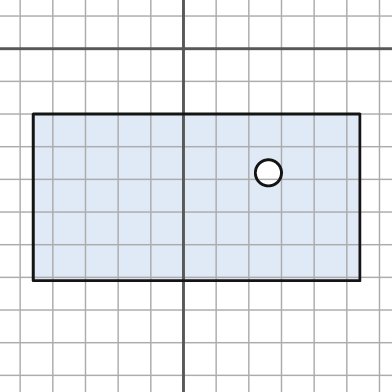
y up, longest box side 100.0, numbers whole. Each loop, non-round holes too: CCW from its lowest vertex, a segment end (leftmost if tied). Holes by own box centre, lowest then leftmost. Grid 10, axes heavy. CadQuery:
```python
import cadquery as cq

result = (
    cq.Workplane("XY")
    .moveTo(-46.0, -71.0)
    .lineTo(54.0, -71.0)
    .lineTo(54.0, -20.0)
    .lineTo(-46.0, -20.0)
    .close()
    .moveTo(26.0, -38.0)
    .circle(4.0)
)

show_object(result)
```